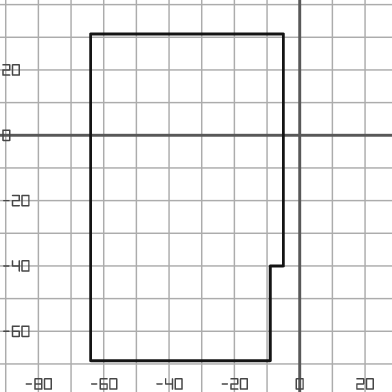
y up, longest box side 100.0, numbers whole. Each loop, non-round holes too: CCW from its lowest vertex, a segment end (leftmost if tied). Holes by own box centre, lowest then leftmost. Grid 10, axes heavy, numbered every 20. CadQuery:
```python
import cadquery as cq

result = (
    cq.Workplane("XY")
    .moveTo(-64.0, -69.0)
    .lineTo(-9.0, -69.0)
    .lineTo(-9.0, -40.0)
    .lineTo(-5.0, -40.0)
    .lineTo(-5.0, 31.0)
    .lineTo(-64.0, 31.0)
    .close()
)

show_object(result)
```